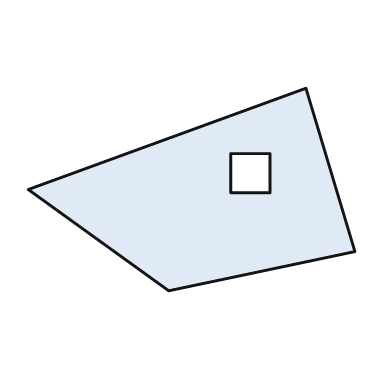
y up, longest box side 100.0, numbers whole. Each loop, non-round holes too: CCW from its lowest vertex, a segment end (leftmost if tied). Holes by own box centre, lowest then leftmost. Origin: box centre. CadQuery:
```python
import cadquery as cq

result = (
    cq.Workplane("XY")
    .moveTo(-7.0, -31.0)
    .lineTo(50.0, -19.0)
    .lineTo(35.0, 31.0)
    .lineTo(-50.0, 0.0)
    .close()
    .moveTo(12.0, -1.0)
    .lineTo(24.0, -1.0)
    .lineTo(24.0, 11.0)
    .lineTo(12.0, 11.0)
    .close()
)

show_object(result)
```